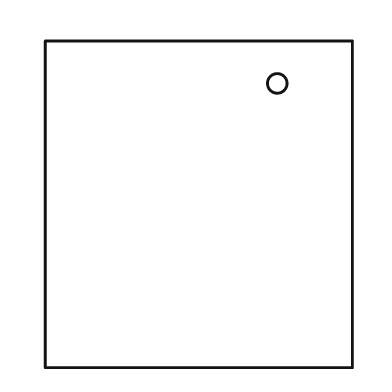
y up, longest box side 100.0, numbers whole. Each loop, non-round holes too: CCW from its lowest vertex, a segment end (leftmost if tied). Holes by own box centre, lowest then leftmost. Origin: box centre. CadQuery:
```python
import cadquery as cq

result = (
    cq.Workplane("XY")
    .moveTo(-47.0, -50.0)
    .lineTo(47.0, -50.0)
    .lineTo(47.0, 50.0)
    .lineTo(-47.0, 50.0)
    .close()
    .moveTo(24.0, 37.0)
    .circle(3.0)
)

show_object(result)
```